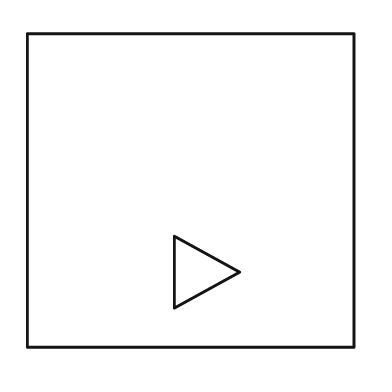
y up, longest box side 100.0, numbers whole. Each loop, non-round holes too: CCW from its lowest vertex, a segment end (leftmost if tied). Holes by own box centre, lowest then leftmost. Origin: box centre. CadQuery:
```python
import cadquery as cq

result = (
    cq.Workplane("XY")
    .moveTo(-50.0, -48.0)
    .lineTo(50.0, -48.0)
    .lineTo(50.0, 48.0)
    .lineTo(-50.0, 48.0)
    .close()
    .moveTo(-5.0, -36.0)
    .lineTo(15.0, -25.0)
    .lineTo(-5.0, -14.0)
    .close()
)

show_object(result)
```